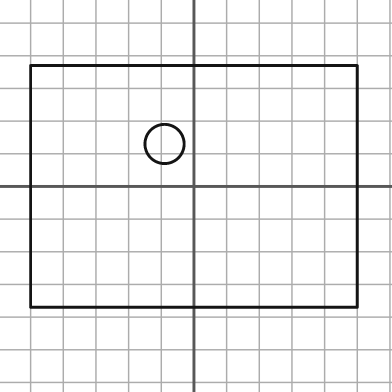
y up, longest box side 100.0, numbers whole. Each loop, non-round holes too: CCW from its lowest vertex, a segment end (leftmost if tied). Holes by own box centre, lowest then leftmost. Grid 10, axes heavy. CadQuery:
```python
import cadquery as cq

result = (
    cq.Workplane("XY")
    .moveTo(-50.0, -37.0)
    .lineTo(50.0, -37.0)
    .lineTo(50.0, 37.0)
    .lineTo(-50.0, 37.0)
    .close()
    .moveTo(-9.0, 13.0)
    .circle(6.0)
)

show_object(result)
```